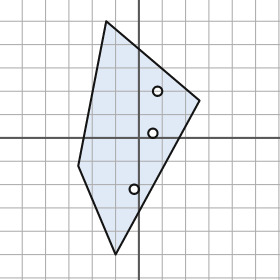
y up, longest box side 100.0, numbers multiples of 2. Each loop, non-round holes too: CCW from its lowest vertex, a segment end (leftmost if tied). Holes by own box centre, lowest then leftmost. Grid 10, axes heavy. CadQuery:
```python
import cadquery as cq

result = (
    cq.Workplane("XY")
    .moveTo(-10.0, -50.0)
    .lineTo(26.0, 16.0)
    .lineTo(-14.0, 50.0)
    .lineTo(-26.0, -12.0)
    .close()
    .moveTo(-2.0, -22.0)
    .circle(2.0)
    .moveTo(6.0, 2.0)
    .circle(2.0)
    .moveTo(8.0, 20.0)
    .circle(2.0)
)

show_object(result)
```